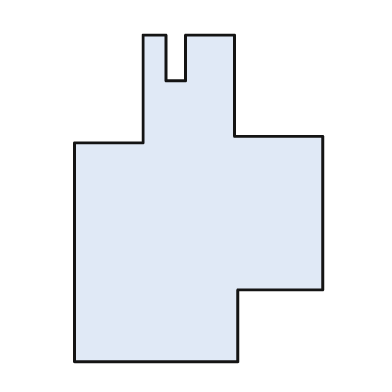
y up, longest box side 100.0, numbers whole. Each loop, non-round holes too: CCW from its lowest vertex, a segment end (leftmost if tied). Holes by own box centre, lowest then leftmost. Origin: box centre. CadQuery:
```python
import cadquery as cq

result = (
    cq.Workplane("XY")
    .moveTo(-38.0, -50.0)
    .lineTo(12.0, -50.0)
    .lineTo(12.0, -28.0)
    .lineTo(38.0, -28.0)
    .lineTo(38.0, 19.0)
    .lineTo(11.0, 19.0)
    .lineTo(11.0, 50.0)
    .lineTo(-4.0, 50.0)
    .lineTo(-4.0, 36.0)
    .lineTo(-10.0, 36.0)
    .lineTo(-10.0, 50.0)
    .lineTo(-17.0, 50.0)
    .lineTo(-17.0, 17.0)
    .lineTo(-38.0, 17.0)
    .close()
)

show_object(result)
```